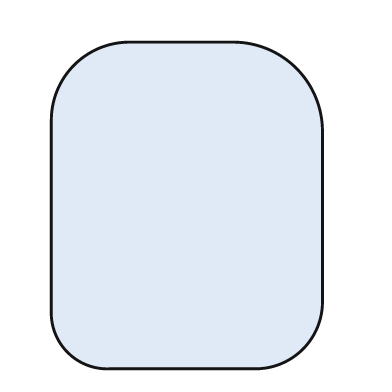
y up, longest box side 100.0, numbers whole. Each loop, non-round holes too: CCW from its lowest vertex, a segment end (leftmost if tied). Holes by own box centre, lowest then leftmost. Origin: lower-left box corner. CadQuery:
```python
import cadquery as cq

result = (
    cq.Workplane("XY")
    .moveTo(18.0, 0.0)
    .lineTo(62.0, 0.0)
    .threePointArc((77.0, 6.0), (83.0, 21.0))
    .lineTo(83.0, 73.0)
    .threePointArc((75.0, 92.0), (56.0, 100.0))
    .lineTo(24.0, 100.0)
    .threePointArc((7.0, 93.0), (0.0, 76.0))
    .lineTo(0.0, 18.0)
    .threePointArc((5.0, 5.0), (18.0, 0.0))
    .close()
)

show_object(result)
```